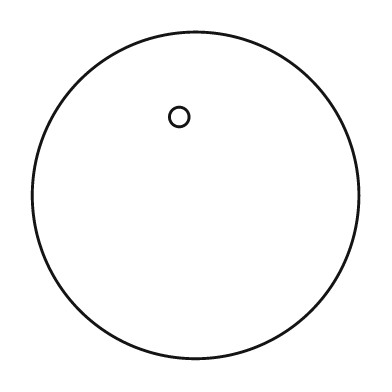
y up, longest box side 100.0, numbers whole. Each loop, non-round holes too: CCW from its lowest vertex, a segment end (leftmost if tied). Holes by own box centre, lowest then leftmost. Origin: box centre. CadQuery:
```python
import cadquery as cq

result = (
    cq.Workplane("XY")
    .moveTo(0.0, 0.0)
    .circle(50.0)
    .moveTo(-5.0, 24.0)
    .circle(3.0)
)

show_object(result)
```